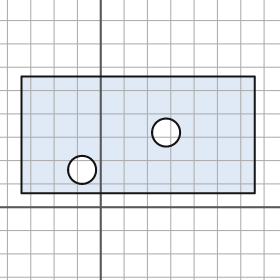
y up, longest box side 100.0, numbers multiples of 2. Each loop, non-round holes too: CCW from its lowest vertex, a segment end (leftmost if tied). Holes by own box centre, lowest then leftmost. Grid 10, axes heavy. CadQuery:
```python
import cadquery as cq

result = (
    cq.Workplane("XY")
    .moveTo(-34.0, 6.0)
    .lineTo(66.0, 6.0)
    .lineTo(66.0, 56.0)
    .lineTo(-34.0, 56.0)
    .close()
    .moveTo(-8.0, 16.0)
    .circle(6.0)
    .moveTo(28.0, 32.0)
    .circle(6.0)
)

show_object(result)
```